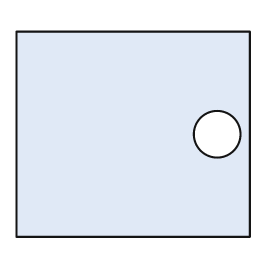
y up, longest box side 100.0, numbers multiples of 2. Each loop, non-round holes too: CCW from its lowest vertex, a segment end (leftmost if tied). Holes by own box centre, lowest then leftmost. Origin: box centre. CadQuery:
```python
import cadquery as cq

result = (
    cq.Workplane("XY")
    .moveTo(-50.0, -44.0)
    .lineTo(50.0, -44.0)
    .lineTo(50.0, 44.0)
    .lineTo(-50.0, 44.0)
    .close()
    .moveTo(36.0, 0.0)
    .circle(10.0)
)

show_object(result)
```